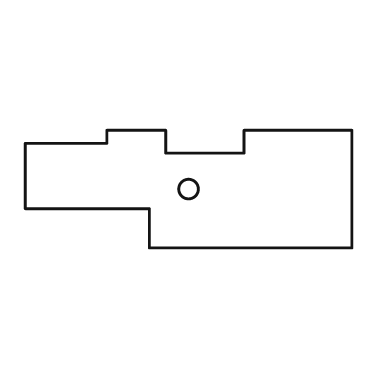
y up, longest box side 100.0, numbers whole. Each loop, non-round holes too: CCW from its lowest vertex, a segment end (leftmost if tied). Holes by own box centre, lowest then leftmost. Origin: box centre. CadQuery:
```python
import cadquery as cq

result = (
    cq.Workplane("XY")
    .moveTo(-12.0, -18.0)
    .lineTo(50.0, -18.0)
    .lineTo(50.0, 18.0)
    .lineTo(17.0, 18.0)
    .lineTo(17.0, 11.0)
    .lineTo(-7.0, 11.0)
    .lineTo(-7.0, 18.0)
    .lineTo(-25.0, 18.0)
    .lineTo(-25.0, 14.0)
    .lineTo(-50.0, 14.0)
    .lineTo(-50.0, -6.0)
    .lineTo(-12.0, -6.0)
    .close()
    .moveTo(0.0, 0.0)
    .circle(3.0)
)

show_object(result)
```